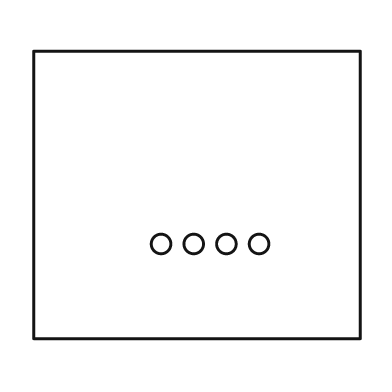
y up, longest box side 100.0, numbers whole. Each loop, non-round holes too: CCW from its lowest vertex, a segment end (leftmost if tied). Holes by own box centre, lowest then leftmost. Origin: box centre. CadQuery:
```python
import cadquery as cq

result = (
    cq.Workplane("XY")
    .moveTo(-50.0, -44.0)
    .lineTo(50.0, -44.0)
    .lineTo(50.0, 44.0)
    .lineTo(-50.0, 44.0)
    .close()
    .moveTo(-11.0, -15.0)
    .circle(3.0)
    .moveTo(-1.0, -15.0)
    .circle(3.0)
    .moveTo(9.0, -15.0)
    .circle(3.0)
    .moveTo(19.0, -15.0)
    .circle(3.0)
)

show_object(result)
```